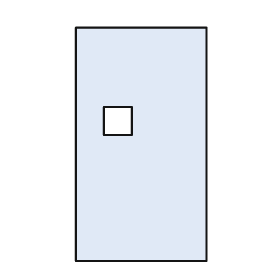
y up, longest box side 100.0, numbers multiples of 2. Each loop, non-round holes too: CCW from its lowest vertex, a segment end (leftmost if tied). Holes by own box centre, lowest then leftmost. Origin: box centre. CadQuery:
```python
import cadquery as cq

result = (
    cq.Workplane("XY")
    .moveTo(-28.0, -50.0)
    .lineTo(28.0, -50.0)
    .lineTo(28.0, 50.0)
    .lineTo(-28.0, 50.0)
    .close()
    .moveTo(-16.0, 4.0)
    .lineTo(-4.0, 4.0)
    .lineTo(-4.0, 16.0)
    .lineTo(-16.0, 16.0)
    .close()
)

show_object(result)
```